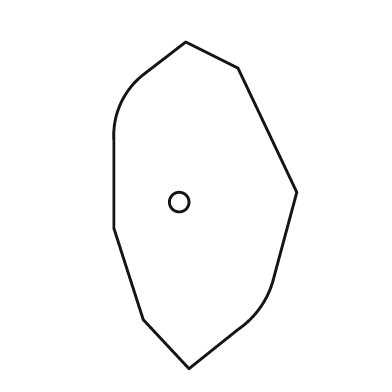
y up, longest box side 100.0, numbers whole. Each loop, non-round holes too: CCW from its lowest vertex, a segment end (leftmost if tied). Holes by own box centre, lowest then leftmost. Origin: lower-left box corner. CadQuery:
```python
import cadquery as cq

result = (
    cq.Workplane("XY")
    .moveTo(23.0, 0.0)
    .lineTo(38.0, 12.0)
    .threePointArc((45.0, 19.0), (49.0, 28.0))
    .lineTo(56.0, 54.0)
    .lineTo(38.0, 92.0)
    .lineTo(22.0, 100.0)
    .lineTo(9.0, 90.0)
    .threePointArc((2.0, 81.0), (0.0, 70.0))
    .lineTo(0.0, 43.0)
    .lineTo(9.0, 15.0)
    .close()
    .moveTo(20.0, 51.0)
    .circle(3.0)
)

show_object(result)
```